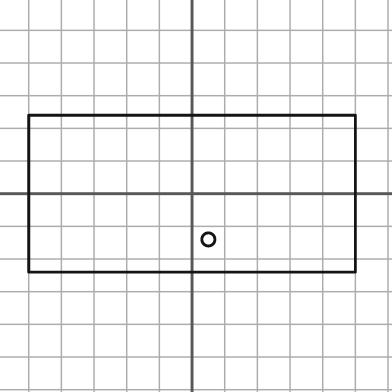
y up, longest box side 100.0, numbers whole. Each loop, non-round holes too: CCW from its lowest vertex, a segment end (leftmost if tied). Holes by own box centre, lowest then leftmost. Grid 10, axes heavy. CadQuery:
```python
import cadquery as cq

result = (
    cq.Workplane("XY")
    .moveTo(-50.0, -24.0)
    .lineTo(50.0, -24.0)
    .lineTo(50.0, 24.0)
    .lineTo(-50.0, 24.0)
    .close()
    .moveTo(5.0, -14.0)
    .circle(2.0)
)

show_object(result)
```